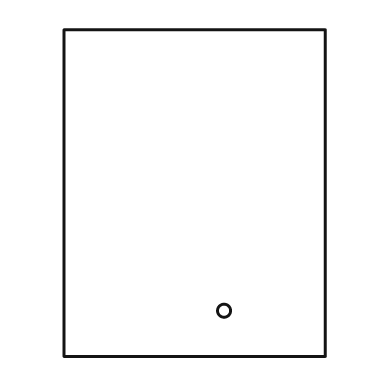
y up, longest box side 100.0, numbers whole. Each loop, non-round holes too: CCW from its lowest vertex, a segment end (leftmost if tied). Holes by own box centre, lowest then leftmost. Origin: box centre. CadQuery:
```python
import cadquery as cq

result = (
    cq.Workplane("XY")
    .moveTo(-40.0, -50.0)
    .lineTo(40.0, -50.0)
    .lineTo(40.0, 50.0)
    .lineTo(-40.0, 50.0)
    .close()
    .moveTo(9.0, -36.0)
    .circle(2.0)
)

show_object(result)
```